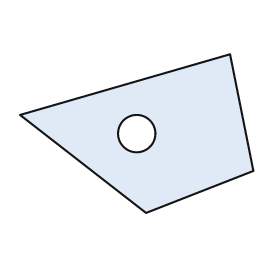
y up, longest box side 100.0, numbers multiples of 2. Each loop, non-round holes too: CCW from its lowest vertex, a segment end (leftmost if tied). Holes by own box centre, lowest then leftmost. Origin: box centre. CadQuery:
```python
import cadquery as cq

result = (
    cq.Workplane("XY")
    .moveTo(4.0, -34.0)
    .lineTo(50.0, -16.0)
    .lineTo(40.0, 34.0)
    .lineTo(-50.0, 8.0)
    .close()
    .moveTo(0.0, 0.0)
    .circle(8.0)
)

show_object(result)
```